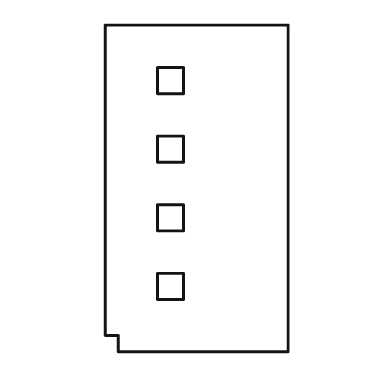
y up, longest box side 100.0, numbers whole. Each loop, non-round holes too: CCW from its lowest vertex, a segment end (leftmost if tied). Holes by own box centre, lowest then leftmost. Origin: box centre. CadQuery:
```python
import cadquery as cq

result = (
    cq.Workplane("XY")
    .moveTo(-24.0, -50.0)
    .lineTo(28.0, -50.0)
    .lineTo(28.0, 50.0)
    .lineTo(-28.0, 50.0)
    .lineTo(-28.0, -45.0)
    .lineTo(-24.0, -45.0)
    .close()
    .moveTo(-12.0, -34.0)
    .lineTo(-4.0, -34.0)
    .lineTo(-4.0, -26.0)
    .lineTo(-12.0, -26.0)
    .close()
    .moveTo(-12.0, -13.0)
    .lineTo(-4.0, -13.0)
    .lineTo(-4.0, -5.0)
    .lineTo(-12.0, -5.0)
    .close()
    .moveTo(-12.0, 8.0)
    .lineTo(-4.0, 8.0)
    .lineTo(-4.0, 16.0)
    .lineTo(-12.0, 16.0)
    .close()
    .moveTo(-12.0, 29.0)
    .lineTo(-4.0, 29.0)
    .lineTo(-4.0, 37.0)
    .lineTo(-12.0, 37.0)
    .close()
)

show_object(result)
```